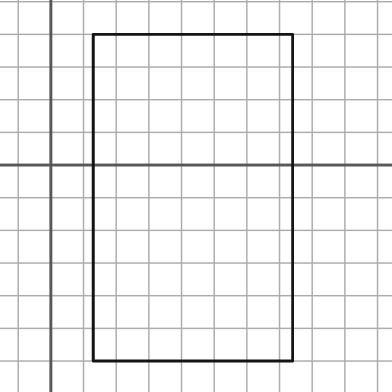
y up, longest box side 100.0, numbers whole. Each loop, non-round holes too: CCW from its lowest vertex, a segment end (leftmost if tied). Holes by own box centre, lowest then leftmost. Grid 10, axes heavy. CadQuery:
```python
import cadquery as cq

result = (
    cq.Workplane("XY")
    .moveTo(13.0, -60.0)
    .lineTo(74.0, -60.0)
    .lineTo(74.0, 40.0)
    .lineTo(13.0, 40.0)
    .close()
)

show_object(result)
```